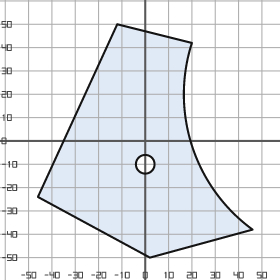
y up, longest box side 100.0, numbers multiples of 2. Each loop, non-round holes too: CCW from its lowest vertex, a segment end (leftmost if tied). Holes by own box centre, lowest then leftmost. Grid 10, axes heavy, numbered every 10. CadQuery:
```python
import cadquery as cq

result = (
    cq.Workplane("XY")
    .moveTo(2.0, -50.0)
    .lineTo(46.0, -38.0)
    .threePointArc((20.0, -2.0), (20.0, 42.0))
    .lineTo(-12.0, 50.0)
    .lineTo(-46.0, -24.0)
    .close()
    .moveTo(0.0, -10.0)
    .circle(4.0)
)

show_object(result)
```